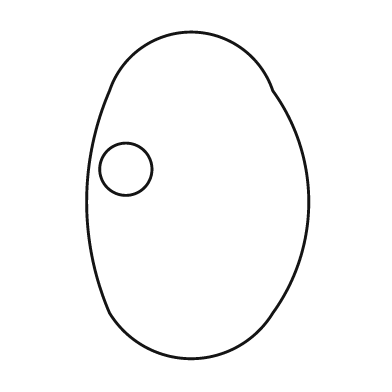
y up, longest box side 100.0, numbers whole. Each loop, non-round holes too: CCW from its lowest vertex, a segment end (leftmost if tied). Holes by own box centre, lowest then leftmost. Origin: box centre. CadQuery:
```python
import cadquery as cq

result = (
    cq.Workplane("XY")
    .moveTo(-27.0, -36.0)
    .threePointArc((-2.0, -50.0), (23.0, -36.0))
    .threePointArc((34.0, -2.0), (23.0, 32.0))
    .threePointArc((-2.0, 50.0), (-27.0, 32.0))
    .threePointArc((-34.0, -2.0), (-27.0, -36.0))
    .close()
    .moveTo(-22.0, 8.0)
    .circle(8.0)
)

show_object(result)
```